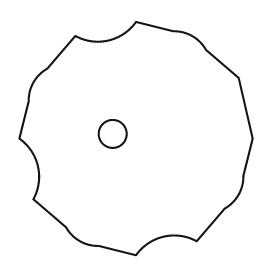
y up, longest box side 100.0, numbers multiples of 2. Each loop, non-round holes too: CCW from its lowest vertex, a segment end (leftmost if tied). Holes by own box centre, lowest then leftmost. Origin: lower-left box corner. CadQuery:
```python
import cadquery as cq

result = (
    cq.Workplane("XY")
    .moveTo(50.0, 0.0)
    .threePointArc((62.0, 8.0), (76.0, 6.0))
    .lineTo(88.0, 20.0)
    .threePointArc((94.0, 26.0), (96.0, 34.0))
    .lineTo(100.0, 50.0)
    .lineTo(94.0, 76.0)
    .lineTo(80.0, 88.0)
    .threePointArc((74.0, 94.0), (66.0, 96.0))
    .lineTo(50.0, 100.0)
    .threePointArc((38.0, 92.0), (24.0, 94.0))
    .lineTo(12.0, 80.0)
    .threePointArc((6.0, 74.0), (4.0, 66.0))
    .lineTo(0.0, 50.0)
    .threePointArc((8.0, 38.0), (6.0, 24.0))
    .lineTo(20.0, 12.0)
    .threePointArc((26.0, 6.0), (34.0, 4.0))
    .close()
    .moveTo(40.0, 52.0)
    .circle(6.0)
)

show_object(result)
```